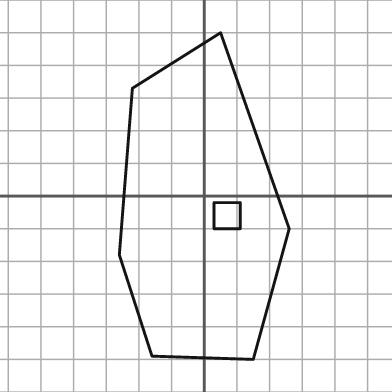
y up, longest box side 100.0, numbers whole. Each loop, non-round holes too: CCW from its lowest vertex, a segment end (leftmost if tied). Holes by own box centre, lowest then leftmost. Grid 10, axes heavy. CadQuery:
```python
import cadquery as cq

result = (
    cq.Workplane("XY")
    .moveTo(15.0, -50.0)
    .lineTo(26.0, -10.0)
    .lineTo(5.0, 50.0)
    .lineTo(-22.0, 33.0)
    .lineTo(-26.0, -18.0)
    .lineTo(-16.0, -49.0)
    .close()
    .moveTo(3.0, -10.0)
    .lineTo(11.0, -10.0)
    .lineTo(11.0, -2.0)
    .lineTo(3.0, -2.0)
    .close()
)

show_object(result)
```